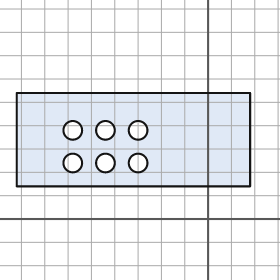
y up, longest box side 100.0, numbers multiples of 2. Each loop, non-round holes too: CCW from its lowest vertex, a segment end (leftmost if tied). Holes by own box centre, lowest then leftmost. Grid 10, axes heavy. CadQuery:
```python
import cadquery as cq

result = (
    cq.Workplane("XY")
    .moveTo(-82.0, 14.0)
    .lineTo(18.0, 14.0)
    .lineTo(18.0, 54.0)
    .lineTo(-82.0, 54.0)
    .close()
    .moveTo(-58.0, 24.0)
    .circle(4.0)
    .moveTo(-44.0, 24.0)
    .circle(4.0)
    .moveTo(-30.0, 24.0)
    .circle(4.0)
    .moveTo(-58.0, 38.0)
    .circle(4.0)
    .moveTo(-44.0, 38.0)
    .circle(4.0)
    .moveTo(-30.0, 38.0)
    .circle(4.0)
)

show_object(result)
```